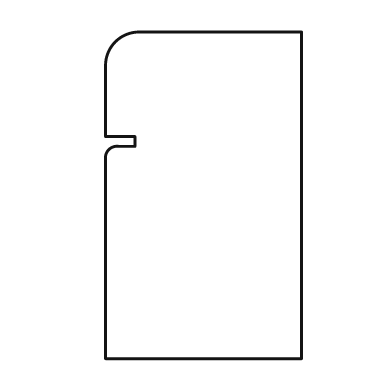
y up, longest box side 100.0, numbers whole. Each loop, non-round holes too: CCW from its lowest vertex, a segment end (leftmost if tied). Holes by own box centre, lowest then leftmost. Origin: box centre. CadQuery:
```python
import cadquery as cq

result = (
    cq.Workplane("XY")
    .moveTo(-30.0, -50.0)
    .lineTo(30.0, -50.0)
    .lineTo(30.0, 50.0)
    .lineTo(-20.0, 50.0)
    .threePointArc((-27.0, 47.0), (-30.0, 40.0))
    .lineTo(-30.0, 18.0)
    .lineTo(-21.0, 18.0)
    .lineTo(-21.0, 15.0)
    .lineTo(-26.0, 15.0)
    .threePointArc((-29.0, 14.0), (-30.0, 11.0))
    .close()
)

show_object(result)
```